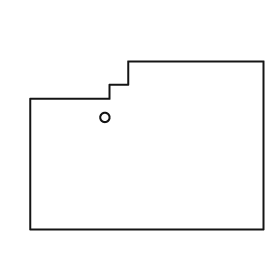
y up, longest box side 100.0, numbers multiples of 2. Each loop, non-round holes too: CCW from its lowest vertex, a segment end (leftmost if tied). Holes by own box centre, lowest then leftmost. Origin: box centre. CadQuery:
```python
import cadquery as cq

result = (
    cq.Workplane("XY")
    .moveTo(-50.0, -36.0)
    .lineTo(50.0, -36.0)
    .lineTo(50.0, 36.0)
    .lineTo(-8.0, 36.0)
    .lineTo(-8.0, 26.0)
    .lineTo(-16.0, 26.0)
    .lineTo(-16.0, 20.0)
    .lineTo(-50.0, 20.0)
    .close()
    .moveTo(-18.0, 12.0)
    .circle(2.0)
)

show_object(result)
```